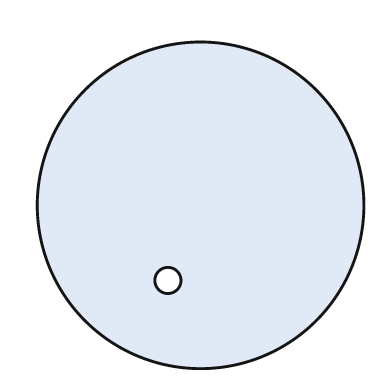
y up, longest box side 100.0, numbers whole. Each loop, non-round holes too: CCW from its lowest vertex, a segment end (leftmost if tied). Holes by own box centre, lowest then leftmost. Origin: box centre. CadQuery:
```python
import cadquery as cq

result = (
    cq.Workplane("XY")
    .moveTo(0.0, 0.0)
    .circle(50.0)
    .moveTo(-10.0, -23.0)
    .circle(4.0)
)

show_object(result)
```